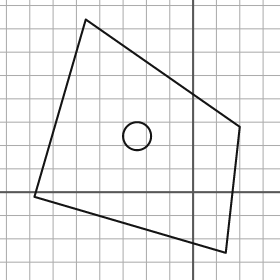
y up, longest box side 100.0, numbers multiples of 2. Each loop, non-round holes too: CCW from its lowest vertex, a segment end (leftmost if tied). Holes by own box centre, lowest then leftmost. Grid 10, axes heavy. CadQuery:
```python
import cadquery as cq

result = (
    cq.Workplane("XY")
    .moveTo(14.0, -26.0)
    .lineTo(20.0, 28.0)
    .lineTo(-46.0, 74.0)
    .lineTo(-68.0, -2.0)
    .close()
    .moveTo(-24.0, 24.0)
    .circle(6.0)
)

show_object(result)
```